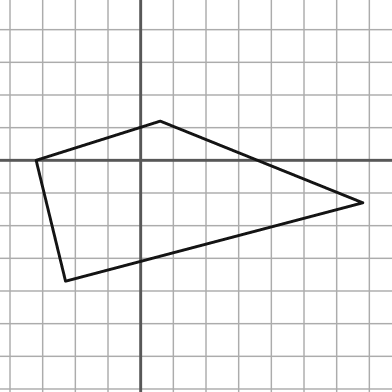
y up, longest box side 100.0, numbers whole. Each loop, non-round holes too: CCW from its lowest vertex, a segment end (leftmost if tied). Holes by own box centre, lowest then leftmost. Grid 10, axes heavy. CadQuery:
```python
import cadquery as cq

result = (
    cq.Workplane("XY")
    .moveTo(-23.0, -37.0)
    .lineTo(68.0, -13.0)
    .lineTo(6.0, 12.0)
    .lineTo(-32.0, 0.0)
    .close()
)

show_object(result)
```